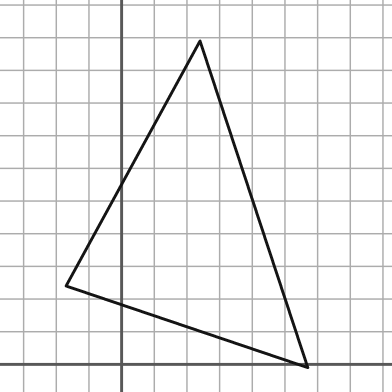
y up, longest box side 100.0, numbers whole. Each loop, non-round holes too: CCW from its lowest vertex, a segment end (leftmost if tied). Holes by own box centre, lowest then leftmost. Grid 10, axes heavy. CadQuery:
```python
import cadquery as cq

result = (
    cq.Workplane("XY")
    .moveTo(57.0, -1.0)
    .lineTo(24.0, 99.0)
    .lineTo(-17.0, 24.0)
    .close()
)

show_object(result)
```